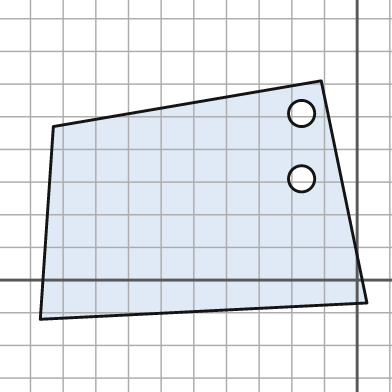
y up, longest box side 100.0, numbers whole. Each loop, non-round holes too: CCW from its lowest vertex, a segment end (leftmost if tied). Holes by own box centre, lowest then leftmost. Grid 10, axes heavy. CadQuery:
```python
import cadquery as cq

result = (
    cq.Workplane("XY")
    .moveTo(-97.0, -12.0)
    .lineTo(3.0, -7.0)
    .lineTo(-11.0, 61.0)
    .lineTo(-93.0, 47.0)
    .close()
    .moveTo(-17.0, 31.0)
    .circle(4.0)
    .moveTo(-17.0, 51.0)
    .circle(4.0)
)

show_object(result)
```